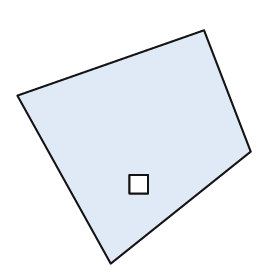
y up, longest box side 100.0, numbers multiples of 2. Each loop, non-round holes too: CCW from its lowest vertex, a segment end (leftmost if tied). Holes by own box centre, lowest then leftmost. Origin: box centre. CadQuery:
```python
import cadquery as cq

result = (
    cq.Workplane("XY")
    .moveTo(-10.0, -50.0)
    .lineTo(50.0, -2.0)
    .lineTo(30.0, 50.0)
    .lineTo(-50.0, 22.0)
    .close()
    .moveTo(-2.0, -20.0)
    .lineTo(6.0, -20.0)
    .lineTo(6.0, -12.0)
    .lineTo(-2.0, -12.0)
    .close()
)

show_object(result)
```